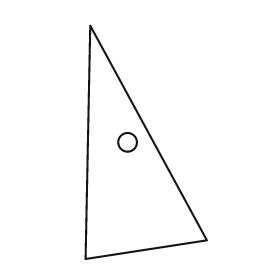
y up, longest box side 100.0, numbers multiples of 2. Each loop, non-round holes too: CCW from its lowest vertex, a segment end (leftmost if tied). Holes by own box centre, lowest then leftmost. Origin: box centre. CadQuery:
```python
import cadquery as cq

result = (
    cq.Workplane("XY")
    .moveTo(-26.0, -50.0)
    .lineTo(26.0, -42.0)
    .lineTo(-24.0, 50.0)
    .close()
    .moveTo(-8.0, 0.0)
    .circle(4.0)
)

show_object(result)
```